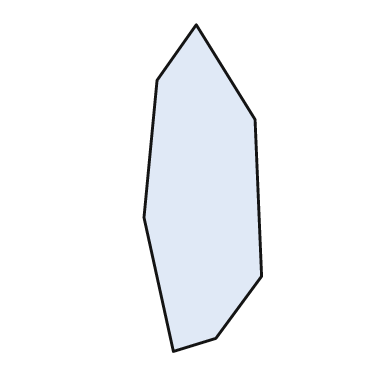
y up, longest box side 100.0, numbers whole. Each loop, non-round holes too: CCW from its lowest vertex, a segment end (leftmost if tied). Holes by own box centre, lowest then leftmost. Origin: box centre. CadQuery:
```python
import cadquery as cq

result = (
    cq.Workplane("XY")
    .moveTo(-9.0, -50.0)
    .lineTo(4.0, -46.0)
    .lineTo(18.0, -27.0)
    .lineTo(16.0, 21.0)
    .lineTo(-2.0, 50.0)
    .lineTo(-14.0, 33.0)
    .lineTo(-18.0, -9.0)
    .close()
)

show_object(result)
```